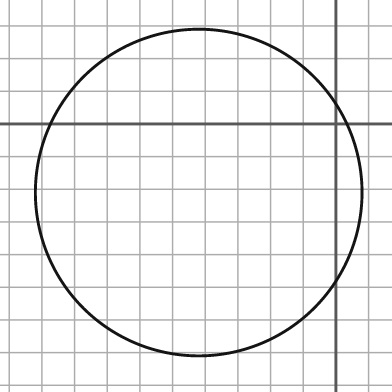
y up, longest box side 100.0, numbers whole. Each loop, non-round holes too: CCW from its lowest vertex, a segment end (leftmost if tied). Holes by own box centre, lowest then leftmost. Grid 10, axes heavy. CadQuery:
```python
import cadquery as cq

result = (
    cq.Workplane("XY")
    .moveTo(-42.0, -21.0)
    .circle(50.0)
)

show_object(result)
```